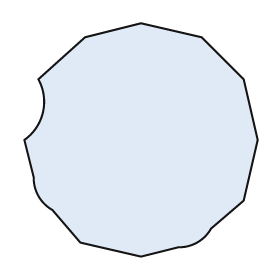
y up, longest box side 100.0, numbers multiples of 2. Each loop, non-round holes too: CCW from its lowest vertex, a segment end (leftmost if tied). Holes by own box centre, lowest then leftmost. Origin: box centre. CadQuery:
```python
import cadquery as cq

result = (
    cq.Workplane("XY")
    .moveTo(0.0, -50.0)
    .lineTo(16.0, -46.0)
    .threePointArc((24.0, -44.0), (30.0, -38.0))
    .lineTo(44.0, -26.0)
    .lineTo(50.0, 0.0)
    .lineTo(44.0, 26.0)
    .lineTo(26.0, 44.0)
    .lineTo(0.0, 50.0)
    .lineTo(-24.0, 44.0)
    .lineTo(-44.0, 26.0)
    .threePointArc((-42.0, 12.0), (-50.0, 0.0))
    .lineTo(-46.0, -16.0)
    .threePointArc((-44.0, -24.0), (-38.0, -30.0))
    .lineTo(-26.0, -44.0)
    .close()
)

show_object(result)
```